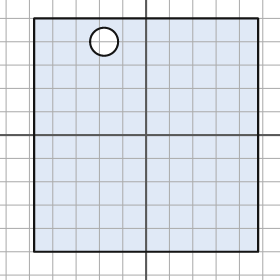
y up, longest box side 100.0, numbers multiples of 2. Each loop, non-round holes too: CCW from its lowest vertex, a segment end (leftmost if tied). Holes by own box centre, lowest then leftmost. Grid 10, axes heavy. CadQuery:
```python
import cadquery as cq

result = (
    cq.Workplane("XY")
    .moveTo(-48.0, -50.0)
    .lineTo(48.0, -50.0)
    .lineTo(48.0, 50.0)
    .lineTo(-48.0, 50.0)
    .close()
    .moveTo(-18.0, 40.0)
    .circle(6.0)
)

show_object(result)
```